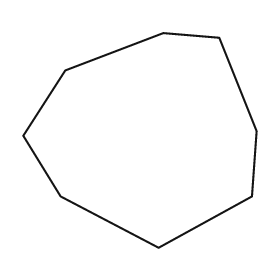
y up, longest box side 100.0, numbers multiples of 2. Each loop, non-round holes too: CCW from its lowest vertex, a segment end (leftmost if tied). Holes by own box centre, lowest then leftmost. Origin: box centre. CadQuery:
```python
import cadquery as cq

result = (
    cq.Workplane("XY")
    .moveTo(8.0, -46.0)
    .lineTo(48.0, -24.0)
    .lineTo(50.0, 4.0)
    .lineTo(34.0, 44.0)
    .lineTo(10.0, 46.0)
    .lineTo(-32.0, 30.0)
    .lineTo(-50.0, 2.0)
    .lineTo(-34.0, -24.0)
    .close()
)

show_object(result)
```